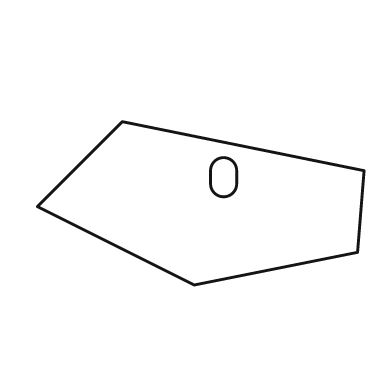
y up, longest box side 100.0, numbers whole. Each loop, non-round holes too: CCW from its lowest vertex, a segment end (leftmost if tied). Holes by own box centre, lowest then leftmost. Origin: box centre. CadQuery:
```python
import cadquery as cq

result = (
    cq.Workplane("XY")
    .moveTo(-2.0, -25.0)
    .lineTo(48.0, -15.0)
    .lineTo(50.0, 10.0)
    .lineTo(-24.0, 25.0)
    .lineTo(-50.0, -1.0)
    .close()
    .moveTo(3.0, 6.0)
    .threePointArc((7.0, 2.0), (11.0, 6.0))
    .lineTo(11.0, 10.0)
    .threePointArc((7.0, 14.0), (3.0, 10.0))
    .close()
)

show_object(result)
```